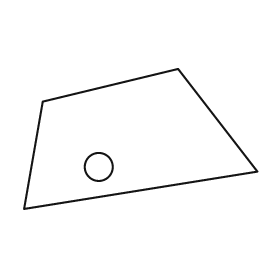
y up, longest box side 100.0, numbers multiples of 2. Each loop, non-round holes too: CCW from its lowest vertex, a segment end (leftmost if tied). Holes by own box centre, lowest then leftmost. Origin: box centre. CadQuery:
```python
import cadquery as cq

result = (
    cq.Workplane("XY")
    .moveTo(-50.0, -30.0)
    .lineTo(50.0, -14.0)
    .lineTo(16.0, 30.0)
    .lineTo(-42.0, 16.0)
    .close()
    .moveTo(-18.0, -12.0)
    .circle(6.0)
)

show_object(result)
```